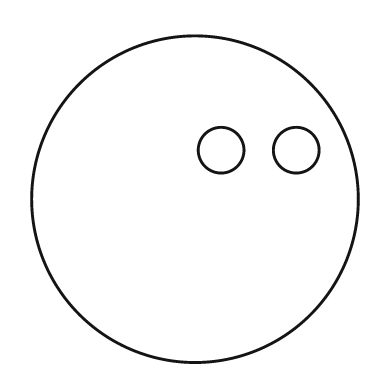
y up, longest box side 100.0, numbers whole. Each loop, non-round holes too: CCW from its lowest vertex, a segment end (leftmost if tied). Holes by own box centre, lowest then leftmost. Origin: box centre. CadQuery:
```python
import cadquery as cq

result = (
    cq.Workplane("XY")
    .moveTo(0.0, 0.0)
    .circle(50.0)
    .moveTo(8.0, 15.0)
    .circle(7.0)
    .moveTo(31.0, 15.0)
    .circle(7.0)
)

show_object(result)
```